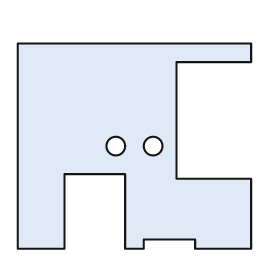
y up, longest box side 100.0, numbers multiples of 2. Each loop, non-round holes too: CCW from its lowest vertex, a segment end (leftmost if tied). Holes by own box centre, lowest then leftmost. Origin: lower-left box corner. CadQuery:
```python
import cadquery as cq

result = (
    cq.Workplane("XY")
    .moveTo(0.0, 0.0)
    .lineTo(20.0, 0.0)
    .lineTo(20.0, 32.0)
    .lineTo(46.0, 32.0)
    .lineTo(46.0, 0.0)
    .lineTo(54.0, 0.0)
    .lineTo(54.0, 4.0)
    .lineTo(76.0, 4.0)
    .lineTo(76.0, 0.0)
    .lineTo(100.0, 0.0)
    .lineTo(100.0, 30.0)
    .lineTo(68.0, 30.0)
    .lineTo(68.0, 80.0)
    .lineTo(100.0, 80.0)
    .lineTo(100.0, 88.0)
    .lineTo(0.0, 88.0)
    .close()
    .moveTo(42.0, 44.0)
    .circle(4.0)
    .moveTo(58.0, 44.0)
    .circle(4.0)
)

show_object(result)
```